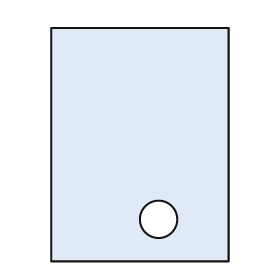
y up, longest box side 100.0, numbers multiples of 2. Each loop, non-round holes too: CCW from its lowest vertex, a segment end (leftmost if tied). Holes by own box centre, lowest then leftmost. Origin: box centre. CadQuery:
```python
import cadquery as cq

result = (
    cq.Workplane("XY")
    .moveTo(-38.0, -50.0)
    .lineTo(38.0, -50.0)
    .lineTo(38.0, 50.0)
    .lineTo(-38.0, 50.0)
    .close()
    .moveTo(8.0, -32.0)
    .circle(8.0)
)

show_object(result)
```